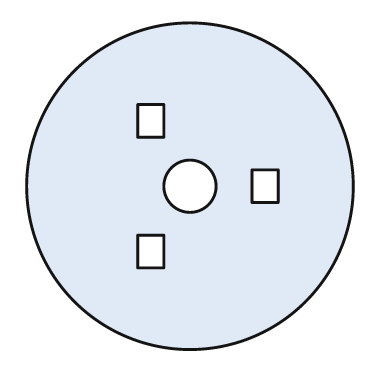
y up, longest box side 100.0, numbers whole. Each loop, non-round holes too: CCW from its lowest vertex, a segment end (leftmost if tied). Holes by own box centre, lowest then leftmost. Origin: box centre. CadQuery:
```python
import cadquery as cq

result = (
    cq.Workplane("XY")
    .moveTo(0.0, 0.0)
    .circle(50.0)
    .moveTo(-16.0, -25.0)
    .lineTo(-8.0, -25.0)
    .lineTo(-8.0, -15.0)
    .lineTo(-16.0, -15.0)
    .close()
    .moveTo(0.0, 0.0)
    .circle(8.0)
    .moveTo(19.0, -5.0)
    .lineTo(27.0, -5.0)
    .lineTo(27.0, 5.0)
    .lineTo(19.0, 5.0)
    .close()
    .moveTo(-16.0, 15.0)
    .lineTo(-8.0, 15.0)
    .lineTo(-8.0, 25.0)
    .lineTo(-16.0, 25.0)
    .close()
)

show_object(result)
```